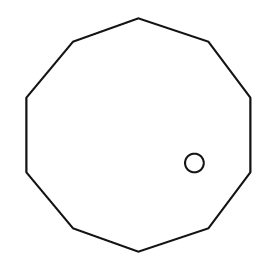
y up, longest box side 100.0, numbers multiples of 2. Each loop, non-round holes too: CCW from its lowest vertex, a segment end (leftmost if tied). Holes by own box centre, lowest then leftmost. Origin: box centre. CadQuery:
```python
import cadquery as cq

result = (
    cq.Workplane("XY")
    .moveTo(0.0, -50.0)
    .lineTo(30.0, -40.0)
    .lineTo(48.0, -16.0)
    .lineTo(48.0, 16.0)
    .lineTo(30.0, 40.0)
    .lineTo(0.0, 50.0)
    .lineTo(-28.0, 40.0)
    .lineTo(-48.0, 16.0)
    .lineTo(-48.0, -16.0)
    .lineTo(-28.0, -40.0)
    .close()
    .moveTo(24.0, -12.0)
    .circle(4.0)
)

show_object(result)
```